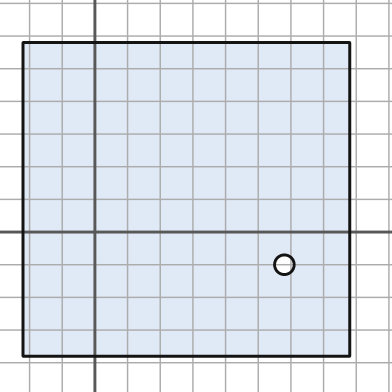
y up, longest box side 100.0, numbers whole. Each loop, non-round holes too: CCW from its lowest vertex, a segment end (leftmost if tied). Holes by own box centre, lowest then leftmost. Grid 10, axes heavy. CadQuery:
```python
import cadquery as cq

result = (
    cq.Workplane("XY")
    .moveTo(-22.0, -38.0)
    .lineTo(78.0, -38.0)
    .lineTo(78.0, 58.0)
    .lineTo(-22.0, 58.0)
    .close()
    .moveTo(58.0, -10.0)
    .circle(3.0)
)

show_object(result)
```